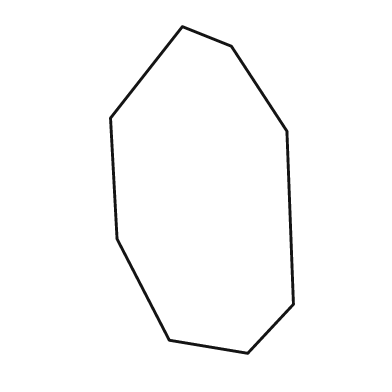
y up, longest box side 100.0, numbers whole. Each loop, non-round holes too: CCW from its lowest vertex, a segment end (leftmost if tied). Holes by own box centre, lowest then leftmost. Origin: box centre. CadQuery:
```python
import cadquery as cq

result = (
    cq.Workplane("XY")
    .moveTo(14.0, -50.0)
    .lineTo(28.0, -35.0)
    .lineTo(26.0, 18.0)
    .lineTo(9.0, 44.0)
    .lineTo(-6.0, 50.0)
    .lineTo(-28.0, 22.0)
    .lineTo(-26.0, -15.0)
    .lineTo(-10.0, -46.0)
    .close()
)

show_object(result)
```